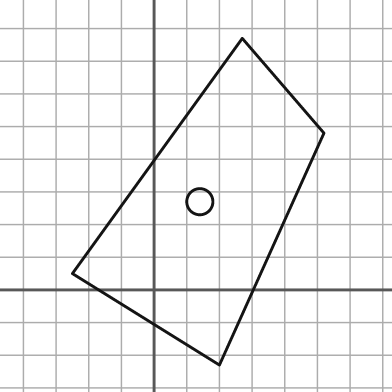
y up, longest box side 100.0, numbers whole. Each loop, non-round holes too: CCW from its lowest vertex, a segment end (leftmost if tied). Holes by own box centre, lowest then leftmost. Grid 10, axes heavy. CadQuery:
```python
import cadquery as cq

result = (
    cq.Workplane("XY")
    .moveTo(20.0, -23.0)
    .lineTo(52.0, 48.0)
    .lineTo(27.0, 77.0)
    .lineTo(-25.0, 5.0)
    .close()
    .moveTo(14.0, 27.0)
    .circle(4.0)
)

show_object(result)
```